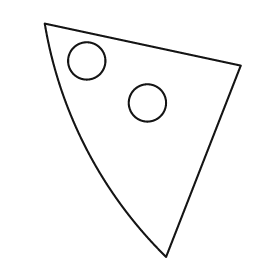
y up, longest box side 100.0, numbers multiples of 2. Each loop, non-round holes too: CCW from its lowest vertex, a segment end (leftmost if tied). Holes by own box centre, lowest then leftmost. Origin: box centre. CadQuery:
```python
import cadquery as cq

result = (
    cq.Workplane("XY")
    .moveTo(10.0, -50.0)
    .lineTo(42.0, 32.0)
    .lineTo(-42.0, 50.0)
    .threePointArc((-24.0, -4.0), (10.0, -50.0))
    .close()
    .moveTo(2.0, 16.0)
    .circle(8.0)
    .moveTo(-24.0, 34.0)
    .circle(8.0)
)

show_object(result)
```